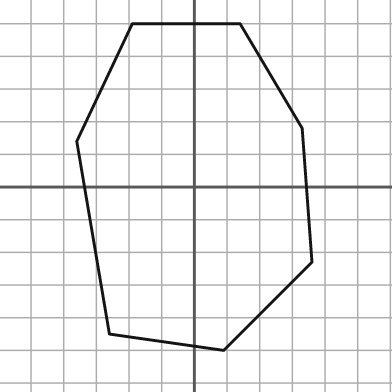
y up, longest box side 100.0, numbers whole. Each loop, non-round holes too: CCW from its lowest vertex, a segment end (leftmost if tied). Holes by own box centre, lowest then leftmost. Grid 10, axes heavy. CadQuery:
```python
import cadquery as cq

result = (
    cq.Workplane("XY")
    .moveTo(9.0, -50.0)
    .lineTo(36.0, -23.0)
    .lineTo(33.0, 18.0)
    .lineTo(14.0, 50.0)
    .lineTo(-19.0, 50.0)
    .lineTo(-36.0, 14.0)
    .lineTo(-26.0, -45.0)
    .close()
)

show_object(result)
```